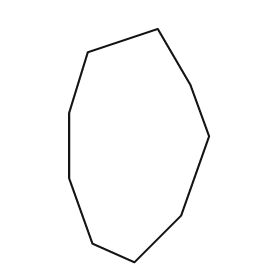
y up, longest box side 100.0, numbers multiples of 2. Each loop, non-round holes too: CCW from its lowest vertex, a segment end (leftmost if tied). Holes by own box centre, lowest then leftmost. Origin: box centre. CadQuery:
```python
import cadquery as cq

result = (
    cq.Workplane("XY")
    .moveTo(-2.0, -50.0)
    .lineTo(18.0, -30.0)
    .lineTo(30.0, 4.0)
    .lineTo(22.0, 26.0)
    .lineTo(8.0, 50.0)
    .lineTo(-22.0, 40.0)
    .lineTo(-30.0, 14.0)
    .lineTo(-30.0, -14.0)
    .lineTo(-20.0, -42.0)
    .close()
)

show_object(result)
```